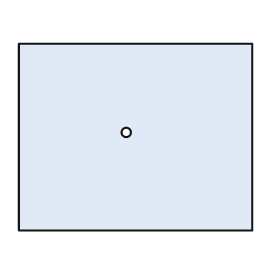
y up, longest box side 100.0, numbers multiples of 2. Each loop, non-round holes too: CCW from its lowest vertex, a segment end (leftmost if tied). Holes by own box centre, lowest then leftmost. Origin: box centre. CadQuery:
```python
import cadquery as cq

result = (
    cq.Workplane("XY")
    .moveTo(-50.0, -40.0)
    .lineTo(50.0, -40.0)
    .lineTo(50.0, 40.0)
    .lineTo(-50.0, 40.0)
    .close()
    .moveTo(-4.0, 2.0)
    .circle(2.0)
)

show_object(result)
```